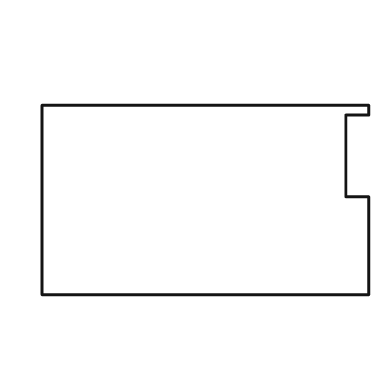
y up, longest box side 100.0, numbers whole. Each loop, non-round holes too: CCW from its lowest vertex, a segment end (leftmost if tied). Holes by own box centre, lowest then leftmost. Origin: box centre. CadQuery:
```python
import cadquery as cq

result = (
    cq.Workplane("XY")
    .moveTo(-50.0, -29.0)
    .lineTo(50.0, -29.0)
    .lineTo(50.0, 1.0)
    .lineTo(43.0, 1.0)
    .lineTo(43.0, 26.0)
    .lineTo(50.0, 26.0)
    .lineTo(50.0, 29.0)
    .lineTo(-50.0, 29.0)
    .close()
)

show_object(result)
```